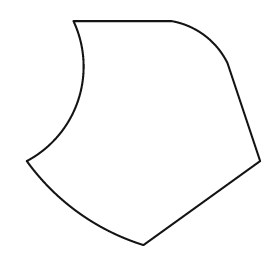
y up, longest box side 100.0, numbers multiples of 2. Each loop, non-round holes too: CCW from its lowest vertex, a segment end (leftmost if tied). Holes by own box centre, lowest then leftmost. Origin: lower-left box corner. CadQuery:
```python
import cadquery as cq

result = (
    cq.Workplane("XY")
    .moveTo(50.0, 0.0)
    .lineTo(100.0, 36.0)
    .lineTo(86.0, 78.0)
    .threePointArc((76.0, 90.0), (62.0, 96.0))
    .lineTo(20.0, 96.0)
    .threePointArc((22.0, 62.0), (0.0, 36.0))
    .threePointArc((22.0, 14.0), (50.0, 0.0))
    .close()
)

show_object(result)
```